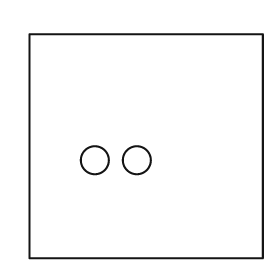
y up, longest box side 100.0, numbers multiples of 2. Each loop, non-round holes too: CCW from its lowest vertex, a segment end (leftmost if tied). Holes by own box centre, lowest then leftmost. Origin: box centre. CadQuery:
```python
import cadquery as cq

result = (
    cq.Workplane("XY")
    .moveTo(-50.0, -48.0)
    .lineTo(50.0, -48.0)
    .lineTo(50.0, 48.0)
    .lineTo(-50.0, 48.0)
    .close()
    .moveTo(-22.0, -6.0)
    .circle(6.0)
    .moveTo(-4.0, -6.0)
    .circle(6.0)
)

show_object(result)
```